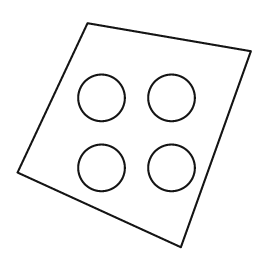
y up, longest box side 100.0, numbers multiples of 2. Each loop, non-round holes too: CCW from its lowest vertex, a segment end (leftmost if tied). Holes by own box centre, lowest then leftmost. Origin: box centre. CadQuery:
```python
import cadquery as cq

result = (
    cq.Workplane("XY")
    .moveTo(20.0, -48.0)
    .lineTo(50.0, 36.0)
    .lineTo(-20.0, 48.0)
    .lineTo(-50.0, -16.0)
    .close()
    .moveTo(-14.0, -14.0)
    .circle(10.0)
    .moveTo(16.0, -14.0)
    .circle(10.0)
    .moveTo(-14.0, 16.0)
    .circle(10.0)
    .moveTo(16.0, 16.0)
    .circle(10.0)
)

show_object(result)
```